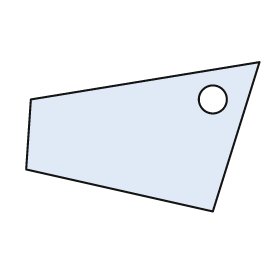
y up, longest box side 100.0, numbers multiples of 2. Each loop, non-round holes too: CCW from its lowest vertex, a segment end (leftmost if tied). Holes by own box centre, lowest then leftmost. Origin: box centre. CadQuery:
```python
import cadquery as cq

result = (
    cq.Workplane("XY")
    .moveTo(30.0, -32.0)
    .lineTo(50.0, 32.0)
    .lineTo(-48.0, 16.0)
    .lineTo(-50.0, -14.0)
    .close()
    .moveTo(30.0, 16.0)
    .circle(6.0)
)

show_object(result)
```